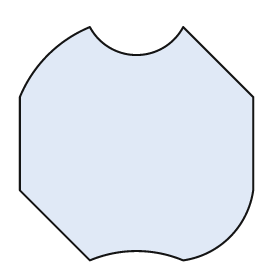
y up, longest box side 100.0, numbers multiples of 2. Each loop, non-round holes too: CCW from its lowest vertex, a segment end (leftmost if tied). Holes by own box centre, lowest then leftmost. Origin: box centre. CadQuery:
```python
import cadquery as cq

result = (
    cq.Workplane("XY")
    .moveTo(-20.0, -50.0)
    .threePointArc((0.0, -46.0), (20.0, -50.0))
    .threePointArc((40.0, -40.0), (50.0, -20.0))
    .lineTo(50.0, 20.0)
    .lineTo(20.0, 50.0)
    .threePointArc((0.0, 38.0), (-20.0, 50.0))
    .threePointArc((-38.0, 38.0), (-50.0, 20.0))
    .lineTo(-50.0, -20.0)
    .close()
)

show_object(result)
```